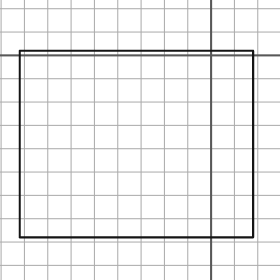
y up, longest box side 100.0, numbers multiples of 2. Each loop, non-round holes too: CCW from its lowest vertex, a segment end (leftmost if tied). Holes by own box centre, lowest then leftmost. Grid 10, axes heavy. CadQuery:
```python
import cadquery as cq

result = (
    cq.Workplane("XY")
    .moveTo(-82.0, -78.0)
    .lineTo(18.0, -78.0)
    .lineTo(18.0, 2.0)
    .lineTo(-82.0, 2.0)
    .close()
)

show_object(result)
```